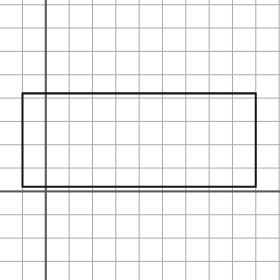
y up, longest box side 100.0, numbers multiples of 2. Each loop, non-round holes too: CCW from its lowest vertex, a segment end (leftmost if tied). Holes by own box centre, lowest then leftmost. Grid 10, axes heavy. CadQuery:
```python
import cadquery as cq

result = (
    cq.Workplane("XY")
    .moveTo(-10.0, 2.0)
    .lineTo(90.0, 2.0)
    .lineTo(90.0, 42.0)
    .lineTo(-10.0, 42.0)
    .close()
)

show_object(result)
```